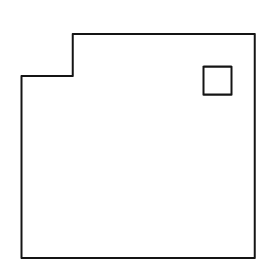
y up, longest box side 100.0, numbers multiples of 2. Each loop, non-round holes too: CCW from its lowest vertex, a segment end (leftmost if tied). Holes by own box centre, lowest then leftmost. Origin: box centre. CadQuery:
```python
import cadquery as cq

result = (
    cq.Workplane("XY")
    .moveTo(-50.0, -48.0)
    .lineTo(50.0, -48.0)
    .lineTo(50.0, 48.0)
    .lineTo(-28.0, 48.0)
    .lineTo(-28.0, 30.0)
    .lineTo(-50.0, 30.0)
    .close()
    .moveTo(28.0, 22.0)
    .lineTo(40.0, 22.0)
    .lineTo(40.0, 34.0)
    .lineTo(28.0, 34.0)
    .close()
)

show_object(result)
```